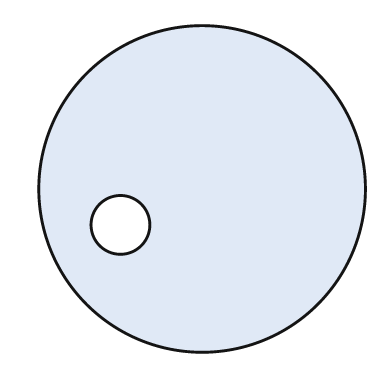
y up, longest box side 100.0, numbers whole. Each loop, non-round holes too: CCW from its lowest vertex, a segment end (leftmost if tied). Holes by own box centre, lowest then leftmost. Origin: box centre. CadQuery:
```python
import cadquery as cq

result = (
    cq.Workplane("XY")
    .moveTo(0.0, 0.0)
    .circle(50.0)
    .moveTo(-25.0, -11.0)
    .circle(9.0)
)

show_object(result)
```